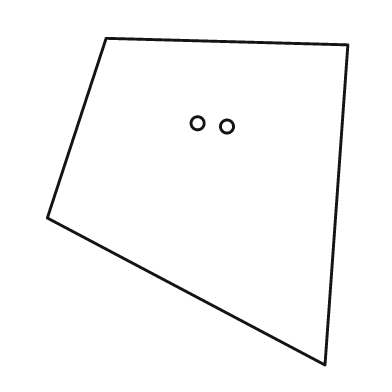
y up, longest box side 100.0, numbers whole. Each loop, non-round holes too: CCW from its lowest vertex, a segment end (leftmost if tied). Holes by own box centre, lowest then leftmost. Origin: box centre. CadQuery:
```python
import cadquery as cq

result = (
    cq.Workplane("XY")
    .moveTo(39.0, -50.0)
    .lineTo(46.0, 48.0)
    .lineTo(-28.0, 50.0)
    .lineTo(-46.0, -5.0)
    .close()
    .moveTo(9.0, 23.0)
    .circle(2.0)
    .moveTo(0.0, 24.0)
    .circle(2.0)
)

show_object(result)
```